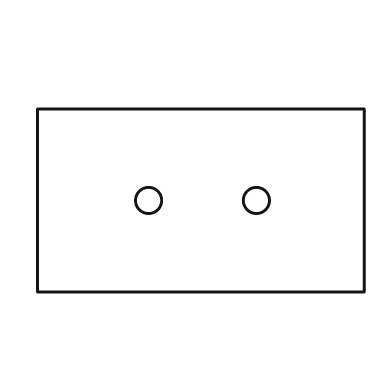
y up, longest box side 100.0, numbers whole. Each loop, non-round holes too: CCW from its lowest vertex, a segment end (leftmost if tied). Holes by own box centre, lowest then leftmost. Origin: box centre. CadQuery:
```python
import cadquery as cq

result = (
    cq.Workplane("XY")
    .moveTo(-50.0, -28.0)
    .lineTo(50.0, -28.0)
    .lineTo(50.0, 28.0)
    .lineTo(-50.0, 28.0)
    .close()
    .moveTo(-16.0, 0.0)
    .circle(4.0)
    .moveTo(17.0, 0.0)
    .circle(4.0)
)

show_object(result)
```